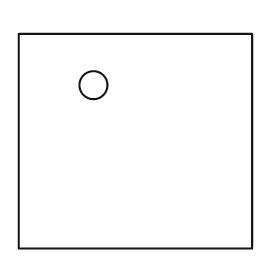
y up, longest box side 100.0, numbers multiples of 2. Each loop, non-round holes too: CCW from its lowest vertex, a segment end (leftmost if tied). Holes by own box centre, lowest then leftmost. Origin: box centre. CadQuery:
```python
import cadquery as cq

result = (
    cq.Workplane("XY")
    .moveTo(-50.0, -46.0)
    .lineTo(50.0, -46.0)
    .lineTo(50.0, 46.0)
    .lineTo(-50.0, 46.0)
    .close()
    .moveTo(-18.0, 24.0)
    .circle(6.0)
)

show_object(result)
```